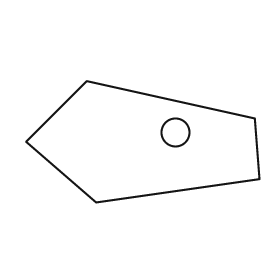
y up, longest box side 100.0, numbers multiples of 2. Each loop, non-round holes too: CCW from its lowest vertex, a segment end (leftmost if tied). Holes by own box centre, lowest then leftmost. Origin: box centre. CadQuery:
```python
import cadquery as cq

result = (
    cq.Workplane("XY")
    .moveTo(-20.0, -26.0)
    .lineTo(50.0, -16.0)
    .lineTo(48.0, 10.0)
    .lineTo(-24.0, 26.0)
    .lineTo(-50.0, 0.0)
    .close()
    .moveTo(14.0, 4.0)
    .circle(6.0)
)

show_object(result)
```